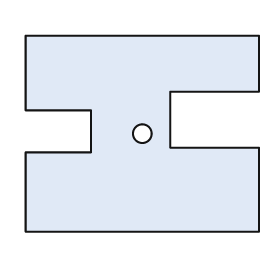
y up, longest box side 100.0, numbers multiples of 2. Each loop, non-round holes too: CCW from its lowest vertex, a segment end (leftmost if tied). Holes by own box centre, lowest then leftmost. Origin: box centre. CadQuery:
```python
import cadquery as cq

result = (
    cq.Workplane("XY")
    .moveTo(-50.0, -42.0)
    .lineTo(50.0, -42.0)
    .lineTo(50.0, -6.0)
    .lineTo(12.0, -6.0)
    .lineTo(12.0, 18.0)
    .lineTo(50.0, 18.0)
    .lineTo(50.0, 42.0)
    .lineTo(-50.0, 42.0)
    .lineTo(-50.0, 10.0)
    .lineTo(-22.0, 10.0)
    .lineTo(-22.0, -8.0)
    .lineTo(-50.0, -8.0)
    .close()
    .moveTo(0.0, 0.0)
    .circle(4.0)
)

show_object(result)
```